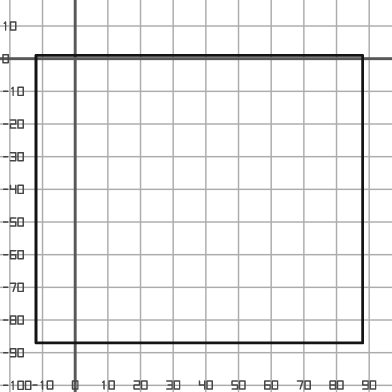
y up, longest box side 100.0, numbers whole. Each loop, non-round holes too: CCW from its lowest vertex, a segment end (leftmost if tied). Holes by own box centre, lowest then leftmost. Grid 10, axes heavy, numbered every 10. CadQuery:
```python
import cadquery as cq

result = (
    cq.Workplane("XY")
    .moveTo(-12.0, -87.0)
    .lineTo(88.0, -87.0)
    .lineTo(88.0, 1.0)
    .lineTo(-12.0, 1.0)
    .close()
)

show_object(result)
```